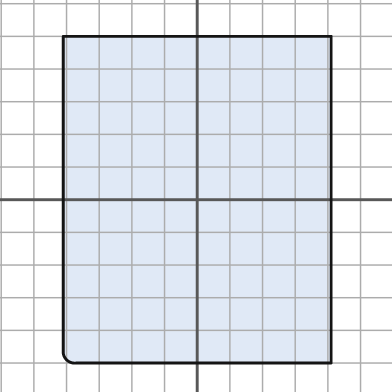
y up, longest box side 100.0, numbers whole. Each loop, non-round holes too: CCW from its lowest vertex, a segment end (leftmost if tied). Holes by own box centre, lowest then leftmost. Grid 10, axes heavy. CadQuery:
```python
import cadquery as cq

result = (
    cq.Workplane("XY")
    .moveTo(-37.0, -50.0)
    .lineTo(41.0, -50.0)
    .lineTo(41.0, 50.0)
    .lineTo(-41.0, 50.0)
    .lineTo(-41.0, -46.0)
    .threePointArc((-40.0, -49.0), (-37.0, -50.0))
    .close()
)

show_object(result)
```